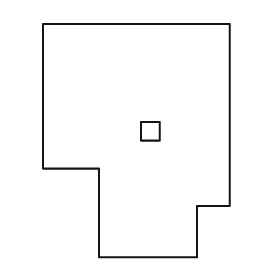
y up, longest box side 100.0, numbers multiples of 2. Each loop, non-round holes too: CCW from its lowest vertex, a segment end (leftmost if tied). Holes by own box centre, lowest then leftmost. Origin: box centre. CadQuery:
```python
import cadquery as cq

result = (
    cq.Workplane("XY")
    .moveTo(-16.0, -50.0)
    .lineTo(26.0, -50.0)
    .lineTo(26.0, -28.0)
    .lineTo(40.0, -28.0)
    .lineTo(40.0, 50.0)
    .lineTo(-40.0, 50.0)
    .lineTo(-40.0, -12.0)
    .lineTo(-16.0, -12.0)
    .close()
    .moveTo(2.0, 0.0)
    .lineTo(10.0, 0.0)
    .lineTo(10.0, 8.0)
    .lineTo(2.0, 8.0)
    .close()
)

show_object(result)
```